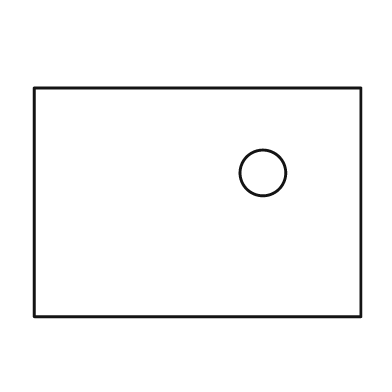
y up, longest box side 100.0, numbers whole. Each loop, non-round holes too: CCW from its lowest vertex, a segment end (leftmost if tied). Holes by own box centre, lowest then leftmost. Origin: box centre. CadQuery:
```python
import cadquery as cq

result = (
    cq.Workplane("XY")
    .moveTo(-50.0, -35.0)
    .lineTo(50.0, -35.0)
    .lineTo(50.0, 35.0)
    .lineTo(-50.0, 35.0)
    .close()
    .moveTo(20.0, 9.0)
    .circle(7.0)
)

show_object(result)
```